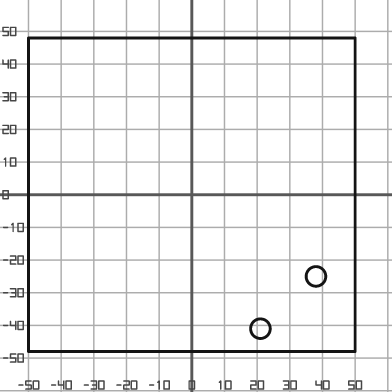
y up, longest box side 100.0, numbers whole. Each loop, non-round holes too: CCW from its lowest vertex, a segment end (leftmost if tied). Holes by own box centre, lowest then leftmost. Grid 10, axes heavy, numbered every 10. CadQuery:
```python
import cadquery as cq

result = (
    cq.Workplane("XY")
    .moveTo(-50.0, -48.0)
    .lineTo(50.0, -48.0)
    .lineTo(50.0, 48.0)
    .lineTo(-50.0, 48.0)
    .close()
    .moveTo(21.0, -41.0)
    .circle(3.0)
    .moveTo(38.0, -25.0)
    .circle(3.0)
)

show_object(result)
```